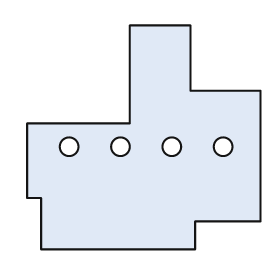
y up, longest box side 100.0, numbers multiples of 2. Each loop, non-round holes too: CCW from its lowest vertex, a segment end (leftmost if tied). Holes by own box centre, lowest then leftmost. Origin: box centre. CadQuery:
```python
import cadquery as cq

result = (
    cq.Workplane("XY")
    .moveTo(-44.0, -48.0)
    .lineTo(22.0, -48.0)
    .lineTo(22.0, -36.0)
    .lineTo(50.0, -36.0)
    .lineTo(50.0, 20.0)
    .lineTo(20.0, 20.0)
    .lineTo(20.0, 48.0)
    .lineTo(-6.0, 48.0)
    .lineTo(-6.0, 6.0)
    .lineTo(-50.0, 6.0)
    .lineTo(-50.0, -26.0)
    .lineTo(-44.0, -26.0)
    .close()
    .moveTo(-32.0, -4.0)
    .circle(4.0)
    .moveTo(-10.0, -4.0)
    .circle(4.0)
    .moveTo(12.0, -4.0)
    .circle(4.0)
    .moveTo(34.0, -4.0)
    .circle(4.0)
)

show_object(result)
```